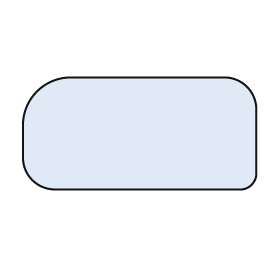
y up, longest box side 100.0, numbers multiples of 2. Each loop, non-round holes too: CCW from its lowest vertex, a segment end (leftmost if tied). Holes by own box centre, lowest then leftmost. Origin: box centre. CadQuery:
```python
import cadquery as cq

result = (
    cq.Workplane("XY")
    .moveTo(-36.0, -24.0)
    .lineTo(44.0, -24.0)
    .threePointArc((48.0, -22.0), (50.0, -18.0))
    .lineTo(50.0, 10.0)
    .threePointArc((46.0, 20.0), (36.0, 24.0))
    .lineTo(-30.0, 24.0)
    .threePointArc((-44.0, 18.0), (-50.0, 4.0))
    .lineTo(-50.0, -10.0)
    .threePointArc((-46.0, -20.0), (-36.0, -24.0))
    .close()
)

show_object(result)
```